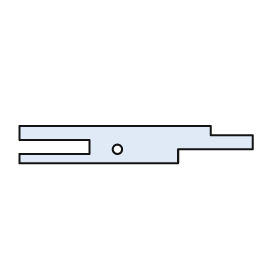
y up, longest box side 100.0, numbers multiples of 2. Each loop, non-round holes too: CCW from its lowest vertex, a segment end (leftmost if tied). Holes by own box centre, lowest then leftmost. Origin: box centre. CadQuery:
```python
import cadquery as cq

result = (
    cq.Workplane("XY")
    .moveTo(-50.0, -8.0)
    .lineTo(18.0, -8.0)
    .lineTo(18.0, -2.0)
    .lineTo(50.0, -2.0)
    .lineTo(50.0, 4.0)
    .lineTo(32.0, 4.0)
    .lineTo(32.0, 8.0)
    .lineTo(-50.0, 8.0)
    .lineTo(-50.0, 2.0)
    .lineTo(-20.0, 2.0)
    .lineTo(-20.0, -4.0)
    .lineTo(-50.0, -4.0)
    .close()
    .moveTo(-8.0, -2.0)
    .circle(2.0)
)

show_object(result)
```